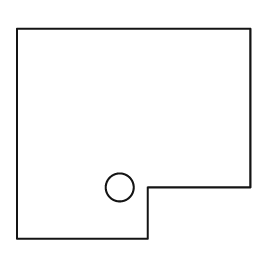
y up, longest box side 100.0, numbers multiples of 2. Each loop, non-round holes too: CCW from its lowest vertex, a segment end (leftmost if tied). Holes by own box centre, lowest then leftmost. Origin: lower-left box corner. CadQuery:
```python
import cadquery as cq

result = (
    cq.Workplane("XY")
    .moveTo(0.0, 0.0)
    .lineTo(56.0, 0.0)
    .lineTo(56.0, 22.0)
    .lineTo(100.0, 22.0)
    .lineTo(100.0, 90.0)
    .lineTo(0.0, 90.0)
    .close()
    .moveTo(44.0, 22.0)
    .circle(6.0)
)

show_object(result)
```